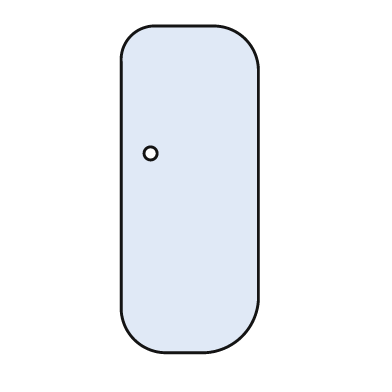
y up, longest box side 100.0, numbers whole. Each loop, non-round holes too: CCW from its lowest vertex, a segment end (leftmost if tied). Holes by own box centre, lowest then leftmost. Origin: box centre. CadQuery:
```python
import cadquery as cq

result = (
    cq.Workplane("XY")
    .moveTo(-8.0, -50.0)
    .lineTo(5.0, -50.0)
    .threePointArc((16.0, -45.0), (21.0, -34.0))
    .lineTo(21.0, 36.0)
    .threePointArc((17.0, 46.0), (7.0, 50.0))
    .lineTo(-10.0, 50.0)
    .threePointArc((-18.0, 47.0), (-21.0, 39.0))
    .lineTo(-21.0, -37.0)
    .threePointArc((-17.0, -46.0), (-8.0, -50.0))
    .close()
    .moveTo(-12.0, 11.0)
    .circle(2.0)
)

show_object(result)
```